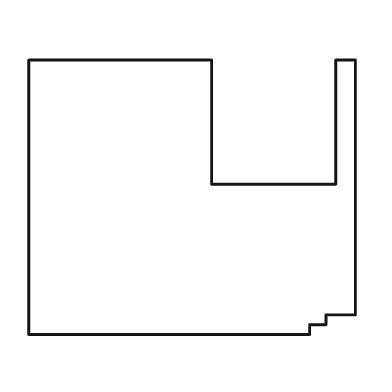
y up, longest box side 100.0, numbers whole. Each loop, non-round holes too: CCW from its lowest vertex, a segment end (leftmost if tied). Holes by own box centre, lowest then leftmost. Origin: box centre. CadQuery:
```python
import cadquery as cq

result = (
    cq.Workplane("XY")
    .moveTo(-50.0, -42.0)
    .lineTo(36.0, -42.0)
    .lineTo(36.0, -39.0)
    .lineTo(41.0, -39.0)
    .lineTo(41.0, -36.0)
    .lineTo(50.0, -36.0)
    .lineTo(50.0, 42.0)
    .lineTo(44.0, 42.0)
    .lineTo(44.0, 4.0)
    .lineTo(6.0, 4.0)
    .lineTo(6.0, 42.0)
    .lineTo(-50.0, 42.0)
    .close()
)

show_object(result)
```